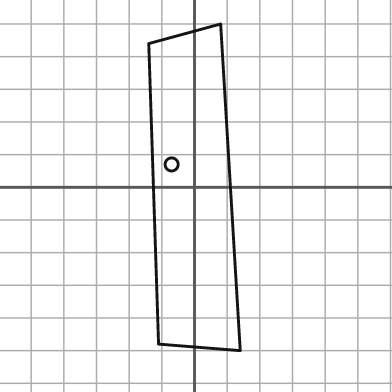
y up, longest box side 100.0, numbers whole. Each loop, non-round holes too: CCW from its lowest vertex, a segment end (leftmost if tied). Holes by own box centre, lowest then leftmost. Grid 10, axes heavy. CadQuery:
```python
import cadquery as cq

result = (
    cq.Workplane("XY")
    .moveTo(14.0, -50.0)
    .lineTo(8.0, 50.0)
    .lineTo(-14.0, 44.0)
    .lineTo(-11.0, -48.0)
    .close()
    .moveTo(-7.0, 7.0)
    .circle(2.0)
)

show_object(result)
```